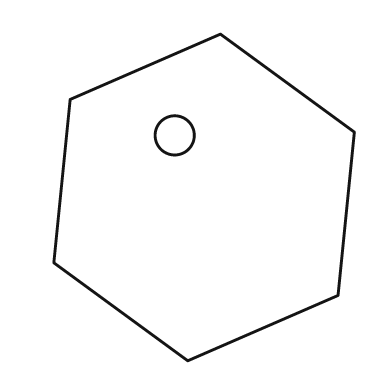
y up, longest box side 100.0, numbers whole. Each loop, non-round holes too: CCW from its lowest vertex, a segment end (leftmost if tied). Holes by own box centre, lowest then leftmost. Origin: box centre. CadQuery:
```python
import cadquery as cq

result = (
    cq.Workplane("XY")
    .moveTo(-5.0, -50.0)
    .lineTo(41.0, -30.0)
    .lineTo(46.0, 20.0)
    .lineTo(5.0, 50.0)
    .lineTo(-41.0, 30.0)
    .lineTo(-46.0, -20.0)
    .close()
    .moveTo(-9.0, 19.0)
    .circle(6.0)
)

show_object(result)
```